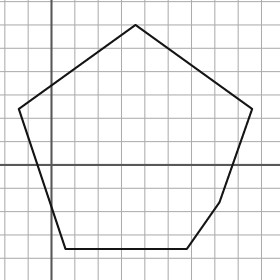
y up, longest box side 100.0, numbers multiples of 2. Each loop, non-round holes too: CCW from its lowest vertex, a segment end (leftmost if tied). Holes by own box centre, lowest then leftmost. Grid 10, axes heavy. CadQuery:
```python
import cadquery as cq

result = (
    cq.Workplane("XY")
    .moveTo(6.0, -36.0)
    .lineTo(58.0, -36.0)
    .lineTo(72.0, -16.0)
    .lineTo(86.0, 24.0)
    .lineTo(36.0, 60.0)
    .lineTo(-14.0, 24.0)
    .close()
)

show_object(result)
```